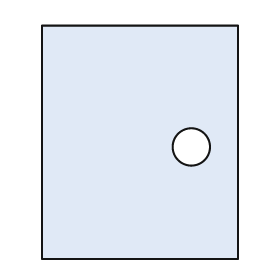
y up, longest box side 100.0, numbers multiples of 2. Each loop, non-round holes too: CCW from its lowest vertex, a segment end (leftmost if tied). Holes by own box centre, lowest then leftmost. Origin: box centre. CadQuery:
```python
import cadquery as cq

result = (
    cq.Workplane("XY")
    .moveTo(-42.0, -50.0)
    .lineTo(42.0, -50.0)
    .lineTo(42.0, 50.0)
    .lineTo(-42.0, 50.0)
    .close()
    .moveTo(22.0, -2.0)
    .circle(8.0)
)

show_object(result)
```